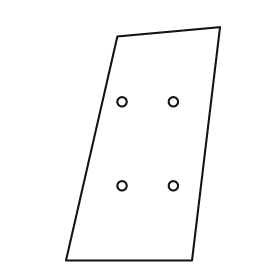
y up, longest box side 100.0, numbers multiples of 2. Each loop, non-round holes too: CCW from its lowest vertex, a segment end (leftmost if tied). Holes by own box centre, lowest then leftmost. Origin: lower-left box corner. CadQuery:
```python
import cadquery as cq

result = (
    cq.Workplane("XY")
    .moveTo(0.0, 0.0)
    .lineTo(54.0, 0.0)
    .lineTo(66.0, 100.0)
    .lineTo(22.0, 96.0)
    .close()
    .moveTo(24.0, 32.0)
    .circle(2.0)
    .moveTo(46.0, 32.0)
    .circle(2.0)
    .moveTo(24.0, 68.0)
    .circle(2.0)
    .moveTo(46.0, 68.0)
    .circle(2.0)
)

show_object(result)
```